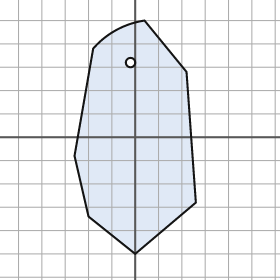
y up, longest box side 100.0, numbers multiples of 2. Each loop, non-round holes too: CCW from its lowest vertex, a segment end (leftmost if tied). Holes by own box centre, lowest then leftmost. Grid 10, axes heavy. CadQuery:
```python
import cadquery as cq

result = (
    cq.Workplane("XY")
    .moveTo(0.0, -50.0)
    .lineTo(26.0, -28.0)
    .lineTo(22.0, 28.0)
    .lineTo(4.0, 50.0)
    .threePointArc((-8.0, 46.0), (-18.0, 38.0))
    .lineTo(-26.0, -8.0)
    .lineTo(-20.0, -34.0)
    .close()
    .moveTo(-2.0, 32.0)
    .circle(2.0)
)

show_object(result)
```